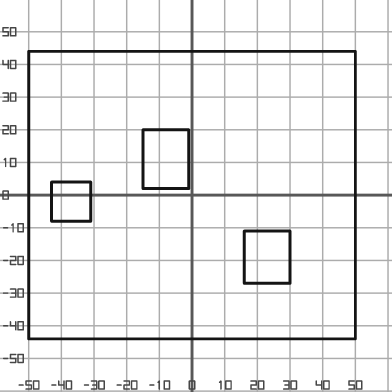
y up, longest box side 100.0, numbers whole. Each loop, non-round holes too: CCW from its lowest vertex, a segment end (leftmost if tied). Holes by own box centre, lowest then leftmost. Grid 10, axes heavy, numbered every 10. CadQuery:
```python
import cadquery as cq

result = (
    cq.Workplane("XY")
    .moveTo(-50.0, -44.0)
    .lineTo(50.0, -44.0)
    .lineTo(50.0, 44.0)
    .lineTo(-50.0, 44.0)
    .close()
    .moveTo(16.0, -27.0)
    .lineTo(30.0, -27.0)
    .lineTo(30.0, -11.0)
    .lineTo(16.0, -11.0)
    .close()
    .moveTo(-43.0, -8.0)
    .lineTo(-31.0, -8.0)
    .lineTo(-31.0, 4.0)
    .lineTo(-43.0, 4.0)
    .close()
    .moveTo(-15.0, 2.0)
    .lineTo(-1.0, 2.0)
    .lineTo(-1.0, 20.0)
    .lineTo(-15.0, 20.0)
    .close()
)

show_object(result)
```